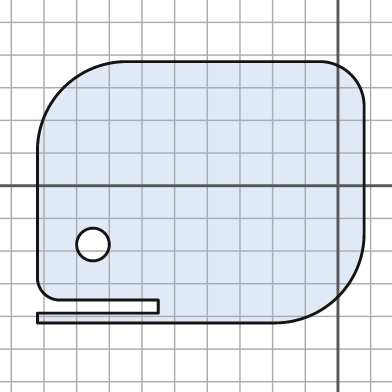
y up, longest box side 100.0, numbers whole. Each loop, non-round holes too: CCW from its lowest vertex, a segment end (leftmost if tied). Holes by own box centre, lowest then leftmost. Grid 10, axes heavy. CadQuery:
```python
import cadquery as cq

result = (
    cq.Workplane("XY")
    .moveTo(-92.0, -42.0)
    .lineTo(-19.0, -42.0)
    .threePointArc((0.0, -34.0), (8.0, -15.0))
    .lineTo(8.0, 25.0)
    .threePointArc((4.0, 34.0), (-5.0, 38.0))
    .lineTo(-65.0, 38.0)
    .threePointArc((-84.0, 30.0), (-92.0, 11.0))
    .lineTo(-92.0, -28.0)
    .threePointArc((-90.0, -33.0), (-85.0, -35.0))
    .lineTo(-55.0, -35.0)
    .lineTo(-55.0, -39.0)
    .lineTo(-92.0, -39.0)
    .close()
    .moveTo(-75.0, -18.0)
    .circle(5.0)
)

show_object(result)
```